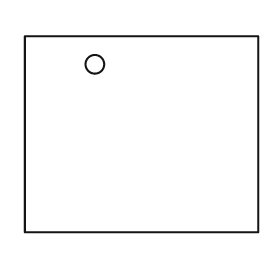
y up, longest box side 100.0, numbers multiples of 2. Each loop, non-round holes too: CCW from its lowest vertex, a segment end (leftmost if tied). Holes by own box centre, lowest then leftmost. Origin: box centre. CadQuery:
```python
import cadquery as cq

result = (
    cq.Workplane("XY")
    .moveTo(-50.0, -42.0)
    .lineTo(50.0, -42.0)
    .lineTo(50.0, 42.0)
    .lineTo(-50.0, 42.0)
    .close()
    .moveTo(-20.0, 30.0)
    .circle(4.0)
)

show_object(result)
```